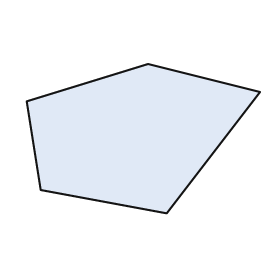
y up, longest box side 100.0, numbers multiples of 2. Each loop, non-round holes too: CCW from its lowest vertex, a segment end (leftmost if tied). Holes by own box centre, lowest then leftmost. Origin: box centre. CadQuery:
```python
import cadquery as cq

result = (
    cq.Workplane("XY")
    .moveTo(10.0, -32.0)
    .lineTo(50.0, 20.0)
    .lineTo(2.0, 32.0)
    .lineTo(-50.0, 16.0)
    .lineTo(-44.0, -22.0)
    .close()
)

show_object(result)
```